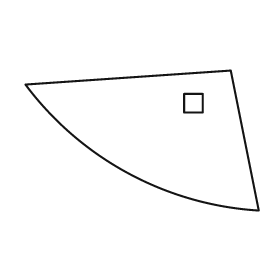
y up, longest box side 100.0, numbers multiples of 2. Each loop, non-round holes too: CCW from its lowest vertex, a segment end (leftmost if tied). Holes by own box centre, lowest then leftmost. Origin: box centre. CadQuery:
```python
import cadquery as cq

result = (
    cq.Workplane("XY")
    .moveTo(50.0, -30.0)
    .lineTo(38.0, 30.0)
    .lineTo(-50.0, 24.0)
    .threePointArc((-6.0, -14.0), (50.0, -30.0))
    .close()
    .moveTo(18.0, 12.0)
    .lineTo(26.0, 12.0)
    .lineTo(26.0, 20.0)
    .lineTo(18.0, 20.0)
    .close()
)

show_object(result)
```